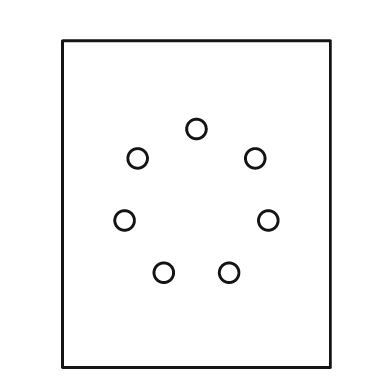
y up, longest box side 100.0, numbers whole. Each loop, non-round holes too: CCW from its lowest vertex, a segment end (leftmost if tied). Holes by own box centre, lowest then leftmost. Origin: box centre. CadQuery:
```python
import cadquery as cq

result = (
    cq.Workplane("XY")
    .moveTo(-41.0, -50.0)
    .lineTo(41.0, -50.0)
    .lineTo(41.0, 50.0)
    .lineTo(-41.0, 50.0)
    .close()
    .moveTo(-10.0, -21.0)
    .circle(3.0)
    .moveTo(10.0, -21.0)
    .circle(3.0)
    .moveTo(-22.0, -5.0)
    .circle(3.0)
    .moveTo(22.0, -5.0)
    .circle(3.0)
    .moveTo(-18.0, 14.0)
    .circle(3.0)
    .moveTo(18.0, 14.0)
    .circle(3.0)
    .moveTo(0.0, 23.0)
    .circle(3.0)
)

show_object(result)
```